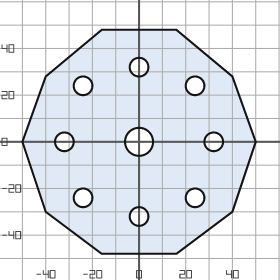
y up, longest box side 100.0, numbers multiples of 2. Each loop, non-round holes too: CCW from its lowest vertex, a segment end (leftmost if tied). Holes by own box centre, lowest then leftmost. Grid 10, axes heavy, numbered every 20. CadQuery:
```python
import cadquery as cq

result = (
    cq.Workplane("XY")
    .moveTo(-16.0, -48.0)
    .lineTo(16.0, -48.0)
    .lineTo(40.0, -30.0)
    .lineTo(50.0, 0.0)
    .lineTo(40.0, 28.0)
    .lineTo(16.0, 48.0)
    .lineTo(-16.0, 48.0)
    .lineTo(-40.0, 28.0)
    .lineTo(-50.0, 0.0)
    .lineTo(-40.0, -30.0)
    .close()
    .moveTo(0.0, -32.0)
    .circle(4.0)
    .moveTo(-24.0, -24.0)
    .circle(4.0)
    .moveTo(24.0, -24.0)
    .circle(4.0)
    .moveTo(-32.0, 0.0)
    .circle(4.0)
    .moveTo(0.0, 0.0)
    .circle(6.0)
    .moveTo(32.0, 0.0)
    .circle(4.0)
    .moveTo(-24.0, 24.0)
    .circle(4.0)
    .moveTo(24.0, 24.0)
    .circle(4.0)
    .moveTo(0.0, 32.0)
    .circle(4.0)
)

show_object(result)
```